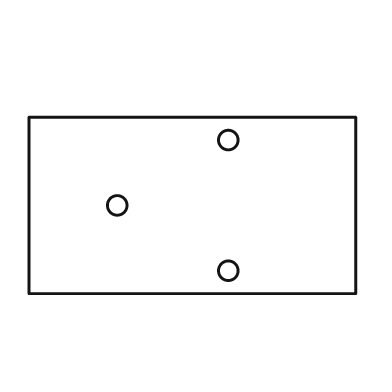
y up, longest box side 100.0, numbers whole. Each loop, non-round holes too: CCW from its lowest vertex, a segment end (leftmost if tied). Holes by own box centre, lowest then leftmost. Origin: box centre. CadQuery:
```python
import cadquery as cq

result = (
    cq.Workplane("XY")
    .moveTo(-50.0, -27.0)
    .lineTo(50.0, -27.0)
    .lineTo(50.0, 27.0)
    .lineTo(-50.0, 27.0)
    .close()
    .moveTo(11.0, -20.0)
    .circle(3.0)
    .moveTo(-23.0, 0.0)
    .circle(3.0)
    .moveTo(11.0, 20.0)
    .circle(3.0)
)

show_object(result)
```